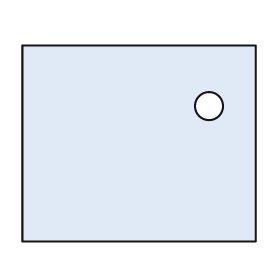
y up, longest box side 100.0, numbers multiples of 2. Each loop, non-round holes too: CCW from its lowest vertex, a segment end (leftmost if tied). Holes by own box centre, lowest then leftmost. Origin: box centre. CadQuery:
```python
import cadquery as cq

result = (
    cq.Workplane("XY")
    .moveTo(-50.0, -42.0)
    .lineTo(50.0, -42.0)
    .lineTo(50.0, 42.0)
    .lineTo(-50.0, 42.0)
    .close()
    .moveTo(30.0, 16.0)
    .circle(6.0)
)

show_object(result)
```